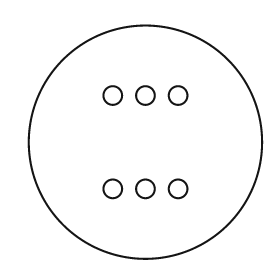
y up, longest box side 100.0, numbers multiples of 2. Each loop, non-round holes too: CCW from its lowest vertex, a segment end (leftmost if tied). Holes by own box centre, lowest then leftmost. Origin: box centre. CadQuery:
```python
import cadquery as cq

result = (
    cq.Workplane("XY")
    .moveTo(0.0, 0.0)
    .circle(50.0)
    .moveTo(-14.0, -20.0)
    .circle(4.0)
    .moveTo(0.0, -20.0)
    .circle(4.0)
    .moveTo(14.0, -20.0)
    .circle(4.0)
    .moveTo(-14.0, 20.0)
    .circle(4.0)
    .moveTo(0.0, 20.0)
    .circle(4.0)
    .moveTo(14.0, 20.0)
    .circle(4.0)
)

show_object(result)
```